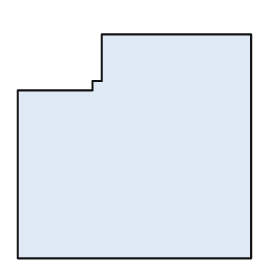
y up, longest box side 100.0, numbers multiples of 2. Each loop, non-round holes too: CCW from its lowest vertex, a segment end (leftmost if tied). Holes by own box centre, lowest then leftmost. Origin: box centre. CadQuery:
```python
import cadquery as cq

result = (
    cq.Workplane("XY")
    .moveTo(-50.0, -48.0)
    .lineTo(50.0, -48.0)
    .lineTo(50.0, 48.0)
    .lineTo(-14.0, 48.0)
    .lineTo(-14.0, 28.0)
    .lineTo(-18.0, 28.0)
    .lineTo(-18.0, 24.0)
    .lineTo(-50.0, 24.0)
    .close()
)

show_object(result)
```